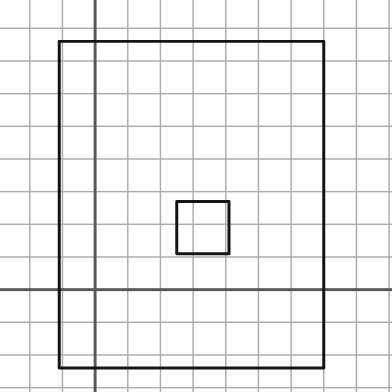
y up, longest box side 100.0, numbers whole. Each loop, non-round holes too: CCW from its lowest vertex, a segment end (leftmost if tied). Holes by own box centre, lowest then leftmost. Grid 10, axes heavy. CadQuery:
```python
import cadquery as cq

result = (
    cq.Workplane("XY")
    .moveTo(-11.0, -24.0)
    .lineTo(70.0, -24.0)
    .lineTo(70.0, 76.0)
    .lineTo(-11.0, 76.0)
    .close()
    .moveTo(25.0, 11.0)
    .lineTo(41.0, 11.0)
    .lineTo(41.0, 27.0)
    .lineTo(25.0, 27.0)
    .close()
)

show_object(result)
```